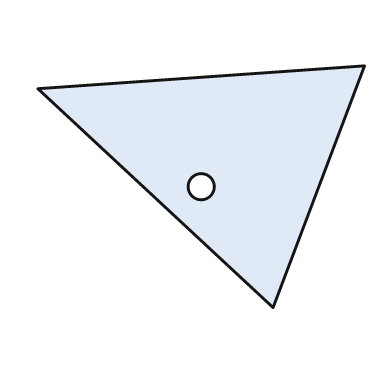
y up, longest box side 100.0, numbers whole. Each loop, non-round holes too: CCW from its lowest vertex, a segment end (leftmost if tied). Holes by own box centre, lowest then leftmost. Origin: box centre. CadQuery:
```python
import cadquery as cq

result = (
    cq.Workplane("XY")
    .moveTo(22.0, -37.0)
    .lineTo(50.0, 37.0)
    .lineTo(-50.0, 30.0)
    .close()
    .moveTo(0.0, 0.0)
    .circle(4.0)
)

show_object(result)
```